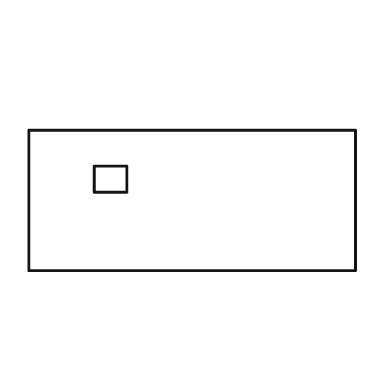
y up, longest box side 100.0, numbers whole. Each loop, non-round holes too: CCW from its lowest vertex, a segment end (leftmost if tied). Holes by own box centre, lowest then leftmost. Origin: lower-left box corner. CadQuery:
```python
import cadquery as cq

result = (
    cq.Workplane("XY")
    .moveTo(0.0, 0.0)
    .lineTo(100.0, 0.0)
    .lineTo(100.0, 43.0)
    .lineTo(0.0, 43.0)
    .close()
    .moveTo(20.0, 24.0)
    .lineTo(30.0, 24.0)
    .lineTo(30.0, 32.0)
    .lineTo(20.0, 32.0)
    .close()
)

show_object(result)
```